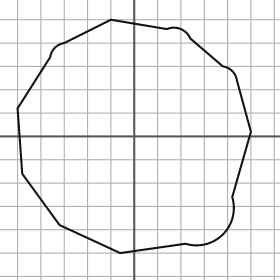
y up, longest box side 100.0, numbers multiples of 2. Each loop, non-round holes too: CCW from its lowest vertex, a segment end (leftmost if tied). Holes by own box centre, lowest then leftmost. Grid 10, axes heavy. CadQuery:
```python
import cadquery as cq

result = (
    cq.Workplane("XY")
    .moveTo(-6.0, -50.0)
    .lineTo(22.0, -46.0)
    .threePointArc((38.0, -42.0), (42.0, -26.0))
    .lineTo(50.0, 2.0)
    .lineTo(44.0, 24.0)
    .threePointArc((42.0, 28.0), (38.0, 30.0))
    .lineTo(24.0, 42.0)
    .threePointArc((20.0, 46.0), (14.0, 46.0))
    .lineTo(-10.0, 50.0)
    .lineTo(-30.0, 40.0)
    .threePointArc((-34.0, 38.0), (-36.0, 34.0))
    .lineTo(-50.0, 12.0)
    .lineTo(-48.0, -16.0)
    .lineTo(-32.0, -38.0)
    .close()
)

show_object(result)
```